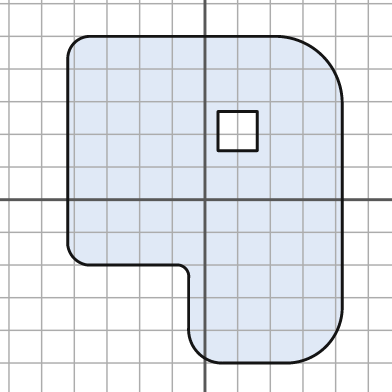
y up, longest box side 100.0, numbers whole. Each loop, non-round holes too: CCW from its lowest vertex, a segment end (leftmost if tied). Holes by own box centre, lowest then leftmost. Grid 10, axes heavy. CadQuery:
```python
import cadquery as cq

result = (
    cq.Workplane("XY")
    .moveTo(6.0, -50.0)
    .lineTo(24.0, -50.0)
    .threePointArc((37.0, -45.0), (42.0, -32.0))
    .lineTo(42.0, 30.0)
    .threePointArc((36.0, 44.0), (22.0, 50.0))
    .lineTo(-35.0, 50.0)
    .threePointArc((-40.0, 48.0), (-42.0, 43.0))
    .lineTo(-42.0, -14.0)
    .threePointArc((-40.0, -18.0), (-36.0, -20.0))
    .lineTo(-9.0, -20.0)
    .threePointArc((-6.0, -21.0), (-5.0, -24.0))
    .lineTo(-5.0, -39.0)
    .threePointArc((-2.0, -47.0), (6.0, -50.0))
    .close()
    .moveTo(4.0, 15.0)
    .lineTo(16.0, 15.0)
    .lineTo(16.0, 27.0)
    .lineTo(4.0, 27.0)
    .close()
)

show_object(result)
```